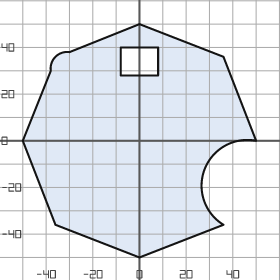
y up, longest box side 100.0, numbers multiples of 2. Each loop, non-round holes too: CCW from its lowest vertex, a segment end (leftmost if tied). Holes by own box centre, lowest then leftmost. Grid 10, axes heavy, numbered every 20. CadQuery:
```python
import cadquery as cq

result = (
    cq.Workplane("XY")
    .moveTo(0.0, -50.0)
    .lineTo(36.0, -36.0)
    .threePointArc((28.0, -12.0), (50.0, 0.0))
    .lineTo(36.0, 36.0)
    .lineTo(0.0, 50.0)
    .lineTo(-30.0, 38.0)
    .threePointArc((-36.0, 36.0), (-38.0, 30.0))
    .lineTo(-50.0, 0.0)
    .lineTo(-36.0, -36.0)
    .close()
    .moveTo(-8.0, 28.0)
    .lineTo(8.0, 28.0)
    .lineTo(8.0, 40.0)
    .lineTo(-8.0, 40.0)
    .close()
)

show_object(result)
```